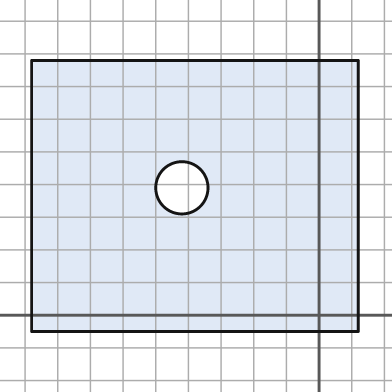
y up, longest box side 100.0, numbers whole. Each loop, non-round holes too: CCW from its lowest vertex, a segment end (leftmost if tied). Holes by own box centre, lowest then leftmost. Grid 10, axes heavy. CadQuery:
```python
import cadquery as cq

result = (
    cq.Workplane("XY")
    .moveTo(-88.0, -5.0)
    .lineTo(12.0, -5.0)
    .lineTo(12.0, 78.0)
    .lineTo(-88.0, 78.0)
    .close()
    .moveTo(-42.0, 39.0)
    .circle(8.0)
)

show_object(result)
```